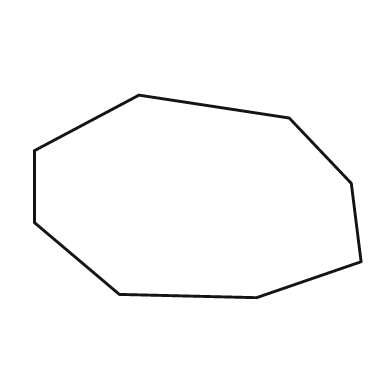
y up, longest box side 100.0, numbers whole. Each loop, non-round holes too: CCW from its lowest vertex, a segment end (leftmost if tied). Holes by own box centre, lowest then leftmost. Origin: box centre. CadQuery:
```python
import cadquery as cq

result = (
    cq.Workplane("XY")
    .moveTo(18.0, -31.0)
    .lineTo(50.0, -20.0)
    .lineTo(47.0, 4.0)
    .lineTo(28.0, 24.0)
    .lineTo(-18.0, 31.0)
    .lineTo(-50.0, 14.0)
    .lineTo(-50.0, -8.0)
    .lineTo(-24.0, -30.0)
    .close()
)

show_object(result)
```